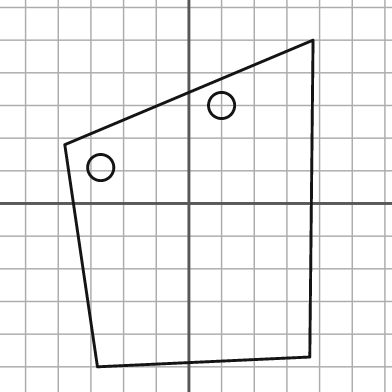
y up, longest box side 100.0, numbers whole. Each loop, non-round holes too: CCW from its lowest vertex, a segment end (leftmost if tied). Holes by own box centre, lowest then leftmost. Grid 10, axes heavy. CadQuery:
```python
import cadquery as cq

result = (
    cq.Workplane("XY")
    .moveTo(-28.0, -50.0)
    .lineTo(37.0, -47.0)
    .lineTo(38.0, 50.0)
    .lineTo(-38.0, 18.0)
    .close()
    .moveTo(-27.0, 11.0)
    .circle(4.0)
    .moveTo(10.0, 30.0)
    .circle(4.0)
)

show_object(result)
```